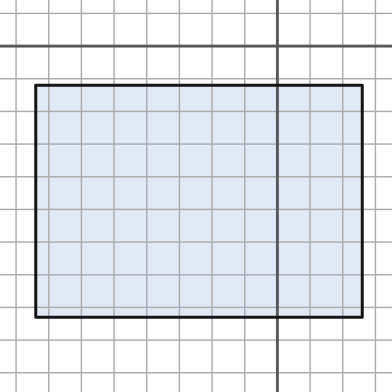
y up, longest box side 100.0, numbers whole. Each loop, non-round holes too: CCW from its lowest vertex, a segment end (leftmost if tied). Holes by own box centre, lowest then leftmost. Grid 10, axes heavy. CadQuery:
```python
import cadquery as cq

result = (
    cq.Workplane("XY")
    .moveTo(-74.0, -83.0)
    .lineTo(26.0, -83.0)
    .lineTo(26.0, -12.0)
    .lineTo(-74.0, -12.0)
    .close()
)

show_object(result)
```